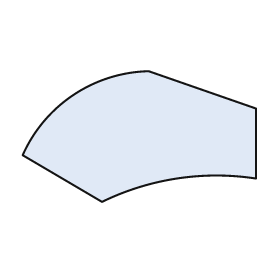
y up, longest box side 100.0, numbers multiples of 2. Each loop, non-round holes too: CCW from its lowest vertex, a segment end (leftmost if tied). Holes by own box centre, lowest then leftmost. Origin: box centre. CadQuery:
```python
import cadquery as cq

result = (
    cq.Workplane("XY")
    .moveTo(-16.0, -28.0)
    .threePointArc((16.0, -18.0), (50.0, -18.0))
    .lineTo(50.0, 12.0)
    .lineTo(4.0, 28.0)
    .threePointArc((-28.0, 18.0), (-50.0, -8.0))
    .close()
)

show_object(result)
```